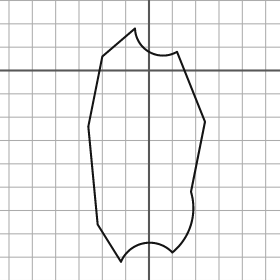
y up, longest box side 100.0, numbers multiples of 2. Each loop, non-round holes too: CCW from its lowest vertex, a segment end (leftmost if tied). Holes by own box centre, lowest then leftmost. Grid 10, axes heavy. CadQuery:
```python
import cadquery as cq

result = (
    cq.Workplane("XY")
    .moveTo(-12.0, -82.0)
    .threePointArc((-2.0, -74.0), (10.0, -78.0))
    .threePointArc((18.0, -66.0), (18.0, -52.0))
    .lineTo(24.0, -22.0)
    .lineTo(12.0, 8.0)
    .threePointArc((0.0, 8.0), (-6.0, 18.0))
    .lineTo(-20.0, 6.0)
    .lineTo(-26.0, -24.0)
    .lineTo(-22.0, -66.0)
    .close()
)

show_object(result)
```